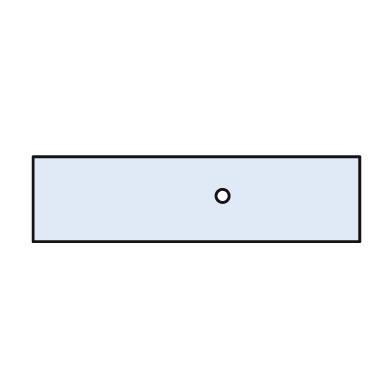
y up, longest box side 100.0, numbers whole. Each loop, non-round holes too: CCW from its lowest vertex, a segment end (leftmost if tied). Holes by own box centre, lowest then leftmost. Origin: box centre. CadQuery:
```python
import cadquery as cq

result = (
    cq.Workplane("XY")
    .moveTo(-50.0, -13.0)
    .lineTo(50.0, -13.0)
    .lineTo(50.0, 13.0)
    .lineTo(-50.0, 13.0)
    .close()
    .moveTo(8.0, 1.0)
    .circle(2.0)
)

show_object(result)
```